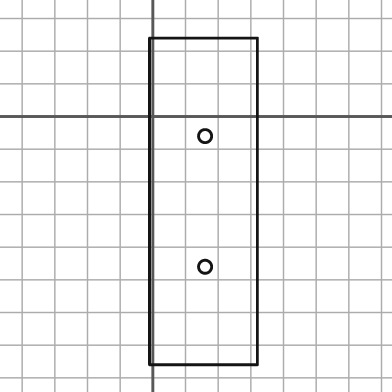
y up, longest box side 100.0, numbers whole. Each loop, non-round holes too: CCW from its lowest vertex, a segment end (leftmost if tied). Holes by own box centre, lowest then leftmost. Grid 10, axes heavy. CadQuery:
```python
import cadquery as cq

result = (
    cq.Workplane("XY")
    .moveTo(-1.0, -76.0)
    .lineTo(32.0, -76.0)
    .lineTo(32.0, 24.0)
    .lineTo(-1.0, 24.0)
    .close()
    .moveTo(16.0, -46.0)
    .circle(2.0)
    .moveTo(16.0, -6.0)
    .circle(2.0)
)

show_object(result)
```